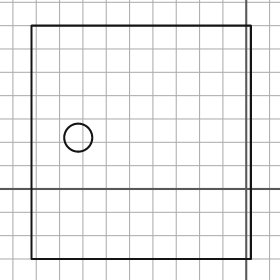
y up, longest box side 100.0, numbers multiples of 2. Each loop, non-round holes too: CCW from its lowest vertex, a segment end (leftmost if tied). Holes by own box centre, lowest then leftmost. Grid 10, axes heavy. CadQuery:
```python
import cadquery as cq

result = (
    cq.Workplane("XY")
    .moveTo(-92.0, -30.0)
    .lineTo(2.0, -30.0)
    .lineTo(2.0, 70.0)
    .lineTo(-92.0, 70.0)
    .close()
    .moveTo(-72.0, 22.0)
    .circle(6.0)
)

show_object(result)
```